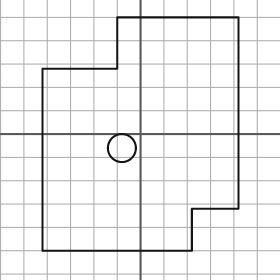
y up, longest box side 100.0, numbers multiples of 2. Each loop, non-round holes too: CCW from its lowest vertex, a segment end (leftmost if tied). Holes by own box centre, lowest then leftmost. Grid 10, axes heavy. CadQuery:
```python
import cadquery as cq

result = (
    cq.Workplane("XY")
    .moveTo(-42.0, -50.0)
    .lineTo(22.0, -50.0)
    .lineTo(22.0, -32.0)
    .lineTo(42.0, -32.0)
    .lineTo(42.0, 50.0)
    .lineTo(-10.0, 50.0)
    .lineTo(-10.0, 28.0)
    .lineTo(-42.0, 28.0)
    .close()
    .moveTo(-8.0, -6.0)
    .circle(6.0)
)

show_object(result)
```